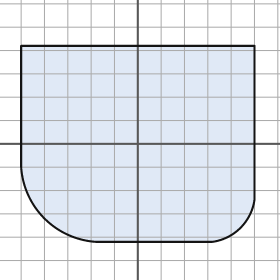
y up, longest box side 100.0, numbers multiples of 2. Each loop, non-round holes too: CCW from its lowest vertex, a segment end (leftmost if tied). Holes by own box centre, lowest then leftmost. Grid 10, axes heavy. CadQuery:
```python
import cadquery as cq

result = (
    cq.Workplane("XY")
    .moveTo(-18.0, -42.0)
    .lineTo(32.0, -42.0)
    .threePointArc((44.0, -36.0), (50.0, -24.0))
    .lineTo(50.0, 42.0)
    .lineTo(-50.0, 42.0)
    .lineTo(-50.0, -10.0)
    .threePointArc((-40.0, -32.0), (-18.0, -42.0))
    .close()
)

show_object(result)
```